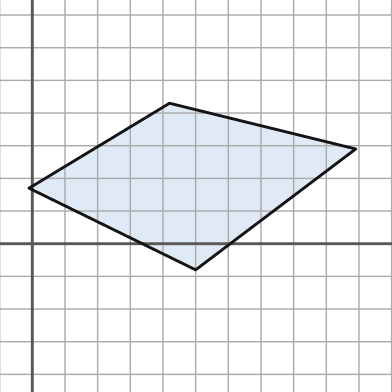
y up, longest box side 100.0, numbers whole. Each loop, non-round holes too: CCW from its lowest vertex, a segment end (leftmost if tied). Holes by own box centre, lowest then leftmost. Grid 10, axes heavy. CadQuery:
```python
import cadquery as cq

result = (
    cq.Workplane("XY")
    .moveTo(50.0, -8.0)
    .lineTo(99.0, 29.0)
    .lineTo(42.0, 43.0)
    .lineTo(-1.0, 17.0)
    .close()
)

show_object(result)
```